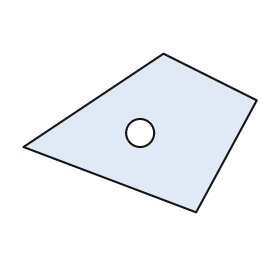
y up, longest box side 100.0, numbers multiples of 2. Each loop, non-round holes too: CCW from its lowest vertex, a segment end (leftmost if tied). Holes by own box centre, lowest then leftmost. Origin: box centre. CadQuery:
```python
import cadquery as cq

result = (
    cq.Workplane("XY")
    .moveTo(24.0, -34.0)
    .lineTo(50.0, 14.0)
    .lineTo(10.0, 34.0)
    .lineTo(-50.0, -6.0)
    .close()
    .moveTo(0.0, 0.0)
    .circle(6.0)
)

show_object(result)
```